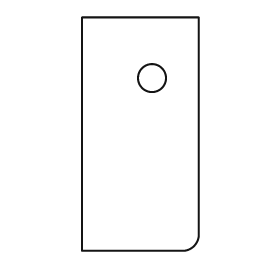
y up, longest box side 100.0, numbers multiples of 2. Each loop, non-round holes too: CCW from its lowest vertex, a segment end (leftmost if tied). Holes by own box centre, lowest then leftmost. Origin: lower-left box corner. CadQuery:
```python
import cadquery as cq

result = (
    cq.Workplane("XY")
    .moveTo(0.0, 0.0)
    .lineTo(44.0, 0.0)
    .threePointArc((48.0, 2.0), (50.0, 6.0))
    .lineTo(50.0, 100.0)
    .lineTo(0.0, 100.0)
    .close()
    .moveTo(30.0, 74.0)
    .circle(6.0)
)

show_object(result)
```